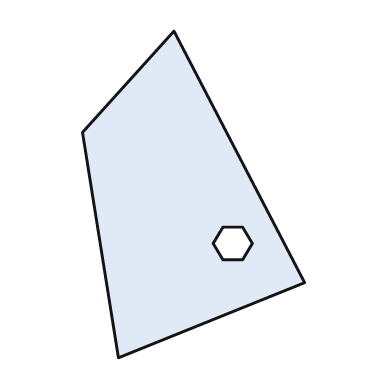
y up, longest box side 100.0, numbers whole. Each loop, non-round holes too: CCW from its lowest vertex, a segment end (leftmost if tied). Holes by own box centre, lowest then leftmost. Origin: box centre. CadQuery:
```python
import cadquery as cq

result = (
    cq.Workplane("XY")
    .moveTo(-23.0, -50.0)
    .lineTo(34.0, -27.0)
    .lineTo(-6.0, 50.0)
    .lineTo(-34.0, 19.0)
    .close()
    .moveTo(9.0, -20.0)
    .lineTo(15.0, -20.0)
    .lineTo(18.0, -15.0)
    .lineTo(15.0, -10.0)
    .lineTo(9.0, -10.0)
    .lineTo(6.0, -15.0)
    .close()
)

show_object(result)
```